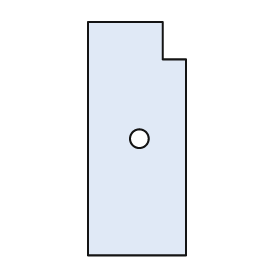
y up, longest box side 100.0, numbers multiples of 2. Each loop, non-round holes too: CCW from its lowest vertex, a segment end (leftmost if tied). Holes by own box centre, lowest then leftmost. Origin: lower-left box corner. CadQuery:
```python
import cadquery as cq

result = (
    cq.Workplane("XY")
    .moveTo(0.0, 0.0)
    .lineTo(42.0, 0.0)
    .lineTo(42.0, 84.0)
    .lineTo(32.0, 84.0)
    .lineTo(32.0, 100.0)
    .lineTo(0.0, 100.0)
    .close()
    .moveTo(22.0, 50.0)
    .circle(4.0)
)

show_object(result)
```